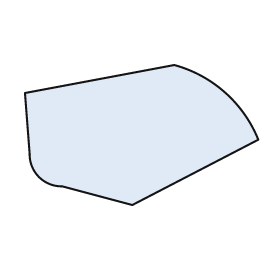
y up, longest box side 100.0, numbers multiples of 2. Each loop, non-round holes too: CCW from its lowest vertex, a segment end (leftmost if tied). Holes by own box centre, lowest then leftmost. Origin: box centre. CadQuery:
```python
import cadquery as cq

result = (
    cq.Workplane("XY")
    .moveTo(-4.0, -30.0)
    .lineTo(50.0, -2.0)
    .threePointArc((36.0, 18.0), (14.0, 30.0))
    .lineTo(-50.0, 18.0)
    .lineTo(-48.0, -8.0)
    .threePointArc((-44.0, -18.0), (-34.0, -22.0))
    .close()
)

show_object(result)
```